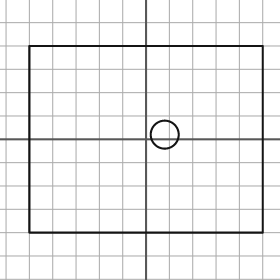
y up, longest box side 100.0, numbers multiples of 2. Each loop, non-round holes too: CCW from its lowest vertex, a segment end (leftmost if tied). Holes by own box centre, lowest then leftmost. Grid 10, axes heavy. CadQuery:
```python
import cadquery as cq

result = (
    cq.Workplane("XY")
    .moveTo(-50.0, -40.0)
    .lineTo(50.0, -40.0)
    .lineTo(50.0, 40.0)
    .lineTo(-50.0, 40.0)
    .close()
    .moveTo(8.0, 2.0)
    .circle(6.0)
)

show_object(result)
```